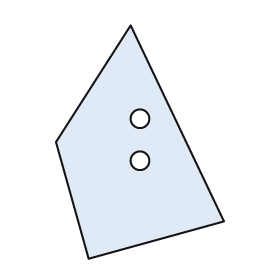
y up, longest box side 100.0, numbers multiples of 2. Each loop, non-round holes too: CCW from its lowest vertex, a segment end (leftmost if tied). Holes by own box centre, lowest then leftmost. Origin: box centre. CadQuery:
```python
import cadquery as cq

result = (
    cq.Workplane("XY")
    .moveTo(-22.0, -50.0)
    .lineTo(36.0, -34.0)
    .lineTo(-4.0, 50.0)
    .lineTo(-36.0, 0.0)
    .close()
    .moveTo(0.0, -8.0)
    .circle(4.0)
    .moveTo(0.0, 10.0)
    .circle(4.0)
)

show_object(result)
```